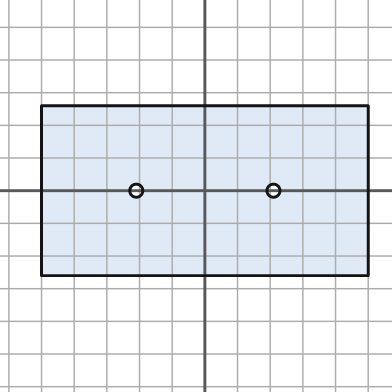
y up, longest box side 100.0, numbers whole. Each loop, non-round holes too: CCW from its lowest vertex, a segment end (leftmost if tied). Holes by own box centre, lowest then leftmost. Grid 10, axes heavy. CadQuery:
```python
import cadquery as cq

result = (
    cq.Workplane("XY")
    .moveTo(-50.0, -26.0)
    .lineTo(50.0, -26.0)
    .lineTo(50.0, 26.0)
    .lineTo(-50.0, 26.0)
    .close()
    .moveTo(-21.0, 0.0)
    .circle(2.0)
    .moveTo(21.0, 0.0)
    .circle(2.0)
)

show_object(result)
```